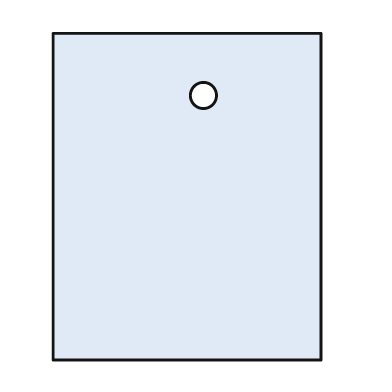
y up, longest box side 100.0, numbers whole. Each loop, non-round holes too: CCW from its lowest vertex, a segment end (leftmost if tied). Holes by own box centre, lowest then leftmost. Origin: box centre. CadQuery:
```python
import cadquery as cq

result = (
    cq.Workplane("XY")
    .moveTo(-41.0, -50.0)
    .lineTo(41.0, -50.0)
    .lineTo(41.0, 50.0)
    .lineTo(-41.0, 50.0)
    .close()
    .moveTo(5.0, 31.0)
    .circle(4.0)
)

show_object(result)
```